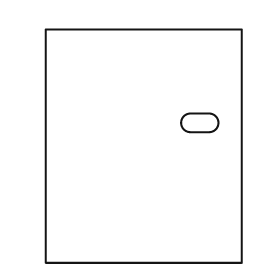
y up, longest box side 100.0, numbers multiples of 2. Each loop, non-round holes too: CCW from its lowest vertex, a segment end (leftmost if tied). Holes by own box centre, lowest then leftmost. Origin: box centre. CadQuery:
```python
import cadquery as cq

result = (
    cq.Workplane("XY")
    .moveTo(-42.0, -50.0)
    .lineTo(42.0, -50.0)
    .lineTo(42.0, 50.0)
    .lineTo(-42.0, 50.0)
    .close()
    .moveTo(20.0, 6.0)
    .lineTo(28.0, 6.0)
    .threePointArc((32.0, 10.0), (28.0, 14.0))
    .lineTo(20.0, 14.0)
    .threePointArc((16.0, 10.0), (20.0, 6.0))
    .close()
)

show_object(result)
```